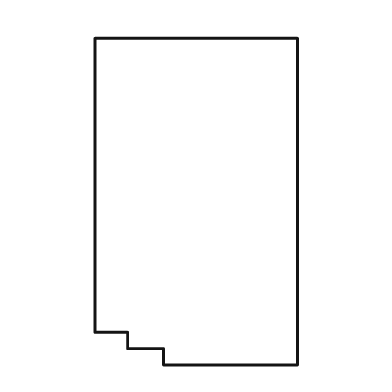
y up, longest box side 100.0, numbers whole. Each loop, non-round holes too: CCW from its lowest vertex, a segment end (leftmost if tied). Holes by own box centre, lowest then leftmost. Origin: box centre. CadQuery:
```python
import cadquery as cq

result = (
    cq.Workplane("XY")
    .moveTo(-10.0, -50.0)
    .lineTo(31.0, -50.0)
    .lineTo(31.0, 50.0)
    .lineTo(-31.0, 50.0)
    .lineTo(-31.0, -40.0)
    .lineTo(-21.0, -40.0)
    .lineTo(-21.0, -45.0)
    .lineTo(-10.0, -45.0)
    .close()
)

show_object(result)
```